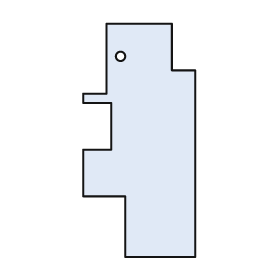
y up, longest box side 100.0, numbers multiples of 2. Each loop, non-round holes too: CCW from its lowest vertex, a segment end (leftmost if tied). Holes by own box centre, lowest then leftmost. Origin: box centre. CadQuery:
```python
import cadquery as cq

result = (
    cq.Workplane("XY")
    .moveTo(-6.0, -50.0)
    .lineTo(24.0, -50.0)
    .lineTo(24.0, 30.0)
    .lineTo(14.0, 30.0)
    .lineTo(14.0, 50.0)
    .lineTo(-14.0, 50.0)
    .lineTo(-14.0, 20.0)
    .lineTo(-24.0, 20.0)
    .lineTo(-24.0, 16.0)
    .lineTo(-12.0, 16.0)
    .lineTo(-12.0, -4.0)
    .lineTo(-24.0, -4.0)
    .lineTo(-24.0, -24.0)
    .lineTo(-6.0, -24.0)
    .close()
    .moveTo(-8.0, 36.0)
    .circle(2.0)
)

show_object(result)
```